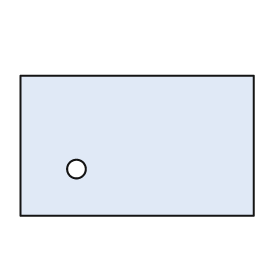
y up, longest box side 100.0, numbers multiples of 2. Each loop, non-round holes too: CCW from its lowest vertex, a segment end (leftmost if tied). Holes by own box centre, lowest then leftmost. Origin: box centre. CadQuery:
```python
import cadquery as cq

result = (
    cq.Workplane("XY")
    .moveTo(-50.0, -30.0)
    .lineTo(50.0, -30.0)
    .lineTo(50.0, 30.0)
    .lineTo(-50.0, 30.0)
    .close()
    .moveTo(-26.0, -10.0)
    .circle(4.0)
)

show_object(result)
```